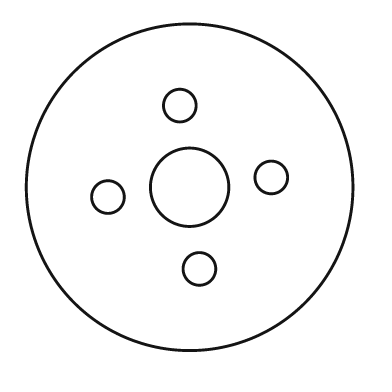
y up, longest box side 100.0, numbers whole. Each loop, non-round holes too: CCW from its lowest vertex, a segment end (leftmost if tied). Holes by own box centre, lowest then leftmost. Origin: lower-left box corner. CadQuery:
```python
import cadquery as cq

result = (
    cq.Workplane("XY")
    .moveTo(50.0, 50.0)
    .circle(50.0)
    .moveTo(53.0, 25.0)
    .circle(5.0)
    .moveTo(25.0, 47.0)
    .circle(5.0)
    .moveTo(50.0, 50.0)
    .circle(12.0)
    .moveTo(75.0, 53.0)
    .circle(5.0)
    .moveTo(47.0, 75.0)
    .circle(5.0)
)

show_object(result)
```